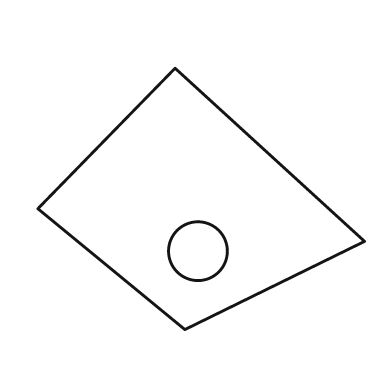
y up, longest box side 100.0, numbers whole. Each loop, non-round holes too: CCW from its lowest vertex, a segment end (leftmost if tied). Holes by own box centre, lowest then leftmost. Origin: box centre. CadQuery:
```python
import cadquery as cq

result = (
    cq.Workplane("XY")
    .moveTo(-5.0, -40.0)
    .lineTo(50.0, -13.0)
    .lineTo(-8.0, 40.0)
    .lineTo(-50.0, -3.0)
    .close()
    .moveTo(-1.0, -16.0)
    .circle(9.0)
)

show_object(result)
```